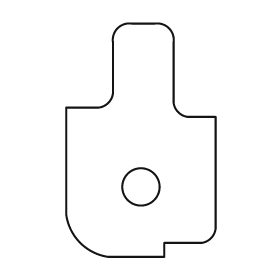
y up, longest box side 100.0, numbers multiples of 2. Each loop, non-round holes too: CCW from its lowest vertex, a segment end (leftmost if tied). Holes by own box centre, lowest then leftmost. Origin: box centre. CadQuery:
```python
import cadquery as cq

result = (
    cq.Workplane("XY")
    .moveTo(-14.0, -50.0)
    .lineTo(10.0, -50.0)
    .lineTo(10.0, -44.0)
    .lineTo(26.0, -44.0)
    .threePointArc((30.0, -42.0), (32.0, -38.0))
    .lineTo(32.0, 10.0)
    .lineTo(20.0, 10.0)
    .threePointArc((16.0, 12.0), (14.0, 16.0))
    .lineTo(14.0, 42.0)
    .threePointArc((12.0, 48.0), (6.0, 50.0))
    .lineTo(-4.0, 50.0)
    .threePointArc((-10.0, 48.0), (-12.0, 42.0))
    .lineTo(-12.0, 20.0)
    .threePointArc((-14.0, 16.0), (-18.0, 14.0))
    .lineTo(-32.0, 14.0)
    .lineTo(-32.0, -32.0)
    .threePointArc((-26.0, -44.0), (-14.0, -50.0))
    .close()
    .moveTo(0.0, -20.0)
    .circle(8.0)
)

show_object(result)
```